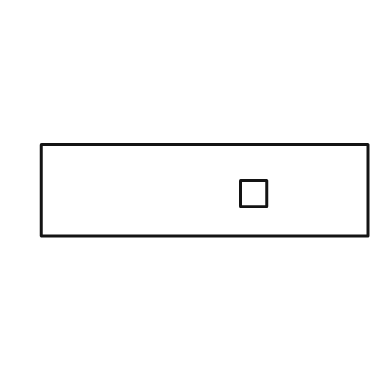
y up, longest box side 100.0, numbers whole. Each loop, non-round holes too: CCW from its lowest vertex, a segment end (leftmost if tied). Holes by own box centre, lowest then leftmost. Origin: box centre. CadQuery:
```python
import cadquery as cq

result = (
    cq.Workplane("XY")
    .moveTo(-50.0, -14.0)
    .lineTo(50.0, -14.0)
    .lineTo(50.0, 14.0)
    .lineTo(-50.0, 14.0)
    .close()
    .moveTo(11.0, -5.0)
    .lineTo(19.0, -5.0)
    .lineTo(19.0, 3.0)
    .lineTo(11.0, 3.0)
    .close()
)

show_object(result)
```